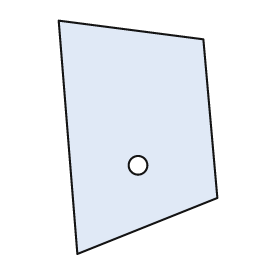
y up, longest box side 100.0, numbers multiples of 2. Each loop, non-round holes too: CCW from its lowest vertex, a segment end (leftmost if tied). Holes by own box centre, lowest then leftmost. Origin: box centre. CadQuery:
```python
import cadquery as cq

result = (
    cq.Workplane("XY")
    .moveTo(-26.0, -50.0)
    .lineTo(34.0, -26.0)
    .lineTo(28.0, 42.0)
    .lineTo(-34.0, 50.0)
    .close()
    .moveTo(0.0, -12.0)
    .circle(4.0)
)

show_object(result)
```